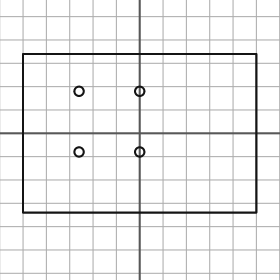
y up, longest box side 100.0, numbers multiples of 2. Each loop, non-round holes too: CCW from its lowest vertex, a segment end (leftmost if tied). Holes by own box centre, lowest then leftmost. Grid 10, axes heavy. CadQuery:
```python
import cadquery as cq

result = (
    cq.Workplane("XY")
    .moveTo(-50.0, -34.0)
    .lineTo(50.0, -34.0)
    .lineTo(50.0, 34.0)
    .lineTo(-50.0, 34.0)
    .close()
    .moveTo(-26.0, -8.0)
    .circle(2.0)
    .moveTo(0.0, -8.0)
    .circle(2.0)
    .moveTo(-26.0, 18.0)
    .circle(2.0)
    .moveTo(0.0, 18.0)
    .circle(2.0)
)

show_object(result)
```